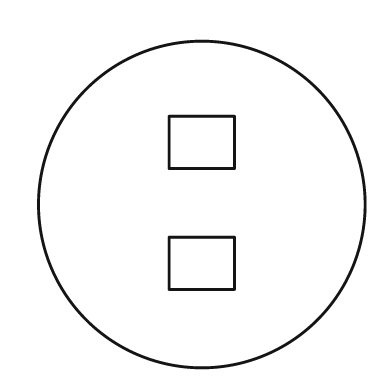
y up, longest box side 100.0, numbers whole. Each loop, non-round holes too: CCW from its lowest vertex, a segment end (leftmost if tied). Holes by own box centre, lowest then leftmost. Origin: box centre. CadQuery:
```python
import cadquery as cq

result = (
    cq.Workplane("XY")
    .moveTo(0.0, 0.0)
    .circle(50.0)
    .moveTo(-10.0, -26.0)
    .lineTo(10.0, -26.0)
    .lineTo(10.0, -10.0)
    .lineTo(-10.0, -10.0)
    .close()
    .moveTo(-10.0, 11.0)
    .lineTo(10.0, 11.0)
    .lineTo(10.0, 27.0)
    .lineTo(-10.0, 27.0)
    .close()
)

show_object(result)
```